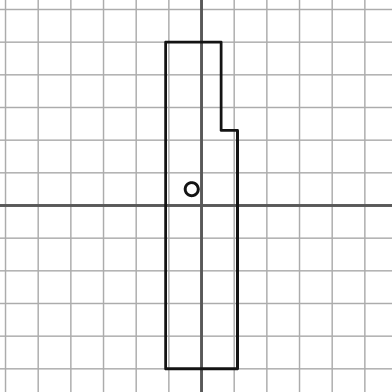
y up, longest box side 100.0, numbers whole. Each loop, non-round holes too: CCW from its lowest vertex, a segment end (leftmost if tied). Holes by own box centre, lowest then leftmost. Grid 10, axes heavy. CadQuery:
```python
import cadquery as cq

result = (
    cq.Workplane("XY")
    .moveTo(-11.0, -50.0)
    .lineTo(11.0, -50.0)
    .lineTo(11.0, 23.0)
    .lineTo(6.0, 23.0)
    .lineTo(6.0, 50.0)
    .lineTo(-11.0, 50.0)
    .close()
    .moveTo(-3.0, 5.0)
    .circle(2.0)
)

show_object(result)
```